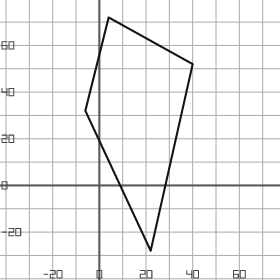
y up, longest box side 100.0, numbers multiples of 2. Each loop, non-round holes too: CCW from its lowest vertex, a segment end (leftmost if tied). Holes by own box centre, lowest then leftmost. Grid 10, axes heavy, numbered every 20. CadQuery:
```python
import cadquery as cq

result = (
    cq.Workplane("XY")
    .moveTo(22.0, -28.0)
    .lineTo(40.0, 52.0)
    .lineTo(4.0, 72.0)
    .lineTo(-6.0, 32.0)
    .close()
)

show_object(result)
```